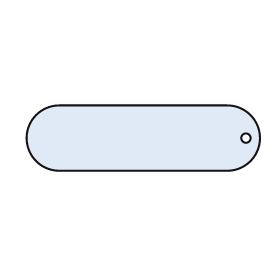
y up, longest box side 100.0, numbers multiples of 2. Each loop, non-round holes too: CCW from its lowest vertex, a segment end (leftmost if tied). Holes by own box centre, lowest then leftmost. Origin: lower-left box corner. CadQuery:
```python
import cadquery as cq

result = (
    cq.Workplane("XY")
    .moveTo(14.0, 0.0)
    .lineTo(86.0, 0.0)
    .threePointArc((100.0, 14.0), (86.0, 28.0))
    .lineTo(14.0, 28.0)
    .threePointArc((0.0, 14.0), (14.0, 0.0))
    .close()
    .moveTo(94.0, 14.0)
    .circle(2.0)
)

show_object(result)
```